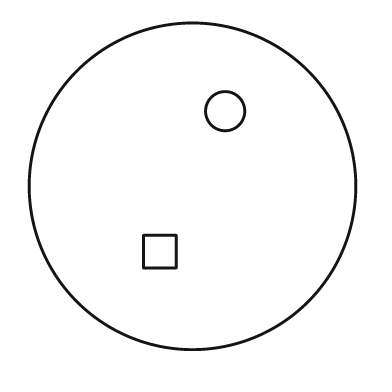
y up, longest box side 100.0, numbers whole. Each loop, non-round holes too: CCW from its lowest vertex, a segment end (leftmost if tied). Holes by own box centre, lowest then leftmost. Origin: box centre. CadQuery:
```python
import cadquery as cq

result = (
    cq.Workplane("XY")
    .moveTo(0.0, 0.0)
    .circle(50.0)
    .moveTo(-15.0, -25.0)
    .lineTo(-5.0, -25.0)
    .lineTo(-5.0, -15.0)
    .lineTo(-15.0, -15.0)
    .close()
    .moveTo(10.0, 23.0)
    .circle(6.0)
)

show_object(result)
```